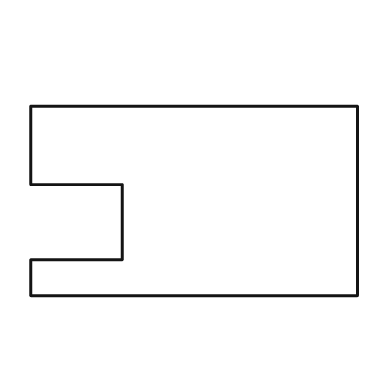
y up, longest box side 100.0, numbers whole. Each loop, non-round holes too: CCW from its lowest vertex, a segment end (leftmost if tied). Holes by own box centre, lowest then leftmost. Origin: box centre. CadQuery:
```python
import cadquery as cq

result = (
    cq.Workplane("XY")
    .moveTo(-50.0, -29.0)
    .lineTo(50.0, -29.0)
    .lineTo(50.0, 29.0)
    .lineTo(-50.0, 29.0)
    .lineTo(-50.0, 5.0)
    .lineTo(-22.0, 5.0)
    .lineTo(-22.0, -18.0)
    .lineTo(-50.0, -18.0)
    .close()
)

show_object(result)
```